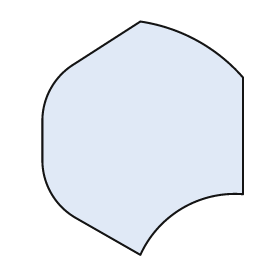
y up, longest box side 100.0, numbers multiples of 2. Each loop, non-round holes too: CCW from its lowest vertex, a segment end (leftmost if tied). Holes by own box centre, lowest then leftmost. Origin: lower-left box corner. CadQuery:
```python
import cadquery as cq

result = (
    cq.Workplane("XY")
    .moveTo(42.0, 0.0)
    .threePointArc((60.0, 20.0), (86.0, 26.0))
    .lineTo(86.0, 76.0)
    .threePointArc((66.0, 92.0), (42.0, 100.0))
    .lineTo(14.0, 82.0)
    .threePointArc((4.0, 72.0), (0.0, 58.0))
    .lineTo(0.0, 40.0)
    .threePointArc((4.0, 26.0), (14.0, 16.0))
    .close()
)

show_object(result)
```